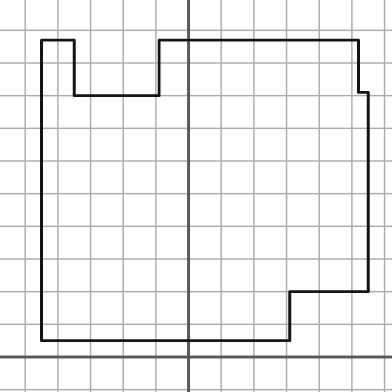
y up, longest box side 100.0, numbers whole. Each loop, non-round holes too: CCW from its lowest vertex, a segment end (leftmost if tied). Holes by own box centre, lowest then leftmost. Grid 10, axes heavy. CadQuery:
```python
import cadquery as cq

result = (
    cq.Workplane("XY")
    .moveTo(-45.0, 5.0)
    .lineTo(31.0, 5.0)
    .lineTo(31.0, 20.0)
    .lineTo(55.0, 20.0)
    .lineTo(55.0, 81.0)
    .lineTo(52.0, 81.0)
    .lineTo(52.0, 97.0)
    .lineTo(-9.0, 97.0)
    .lineTo(-9.0, 80.0)
    .lineTo(-35.0, 80.0)
    .lineTo(-35.0, 97.0)
    .lineTo(-45.0, 97.0)
    .close()
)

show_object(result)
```